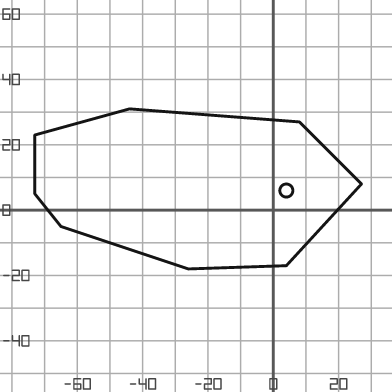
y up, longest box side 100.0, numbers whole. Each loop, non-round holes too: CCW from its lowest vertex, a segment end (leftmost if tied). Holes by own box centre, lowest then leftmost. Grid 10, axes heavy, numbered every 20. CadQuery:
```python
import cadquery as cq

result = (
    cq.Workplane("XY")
    .moveTo(-26.0, -18.0)
    .lineTo(4.0, -17.0)
    .lineTo(27.0, 8.0)
    .lineTo(8.0, 27.0)
    .lineTo(-44.0, 31.0)
    .lineTo(-73.0, 23.0)
    .lineTo(-73.0, 5.0)
    .lineTo(-65.0, -5.0)
    .close()
    .moveTo(4.0, 6.0)
    .circle(2.0)
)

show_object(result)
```